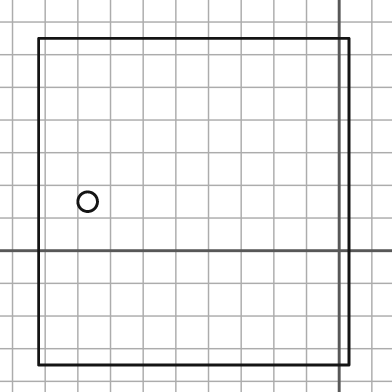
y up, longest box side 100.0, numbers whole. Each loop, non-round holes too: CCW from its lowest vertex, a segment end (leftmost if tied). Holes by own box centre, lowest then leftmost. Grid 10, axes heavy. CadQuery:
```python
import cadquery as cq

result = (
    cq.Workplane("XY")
    .moveTo(-92.0, -35.0)
    .lineTo(3.0, -35.0)
    .lineTo(3.0, 65.0)
    .lineTo(-92.0, 65.0)
    .close()
    .moveTo(-77.0, 15.0)
    .circle(3.0)
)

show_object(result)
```